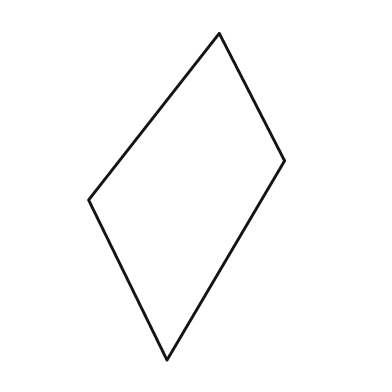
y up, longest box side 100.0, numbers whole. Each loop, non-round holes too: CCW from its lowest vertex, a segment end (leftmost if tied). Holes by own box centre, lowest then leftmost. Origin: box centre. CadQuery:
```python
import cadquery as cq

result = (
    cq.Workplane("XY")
    .moveTo(-6.0, -50.0)
    .lineTo(30.0, 11.0)
    .lineTo(10.0, 50.0)
    .lineTo(-30.0, -1.0)
    .close()
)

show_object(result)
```